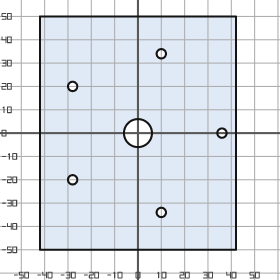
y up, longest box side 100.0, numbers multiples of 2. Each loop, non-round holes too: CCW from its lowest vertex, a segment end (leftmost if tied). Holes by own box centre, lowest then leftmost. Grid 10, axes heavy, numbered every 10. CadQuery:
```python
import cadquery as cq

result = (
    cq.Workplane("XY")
    .moveTo(-42.0, -50.0)
    .lineTo(42.0, -50.0)
    .lineTo(42.0, 50.0)
    .lineTo(-42.0, 50.0)
    .close()
    .moveTo(10.0, -34.0)
    .circle(2.0)
    .moveTo(-28.0, -20.0)
    .circle(2.0)
    .moveTo(0.0, 0.0)
    .circle(6.0)
    .moveTo(36.0, 0.0)
    .circle(2.0)
    .moveTo(-28.0, 20.0)
    .circle(2.0)
    .moveTo(10.0, 34.0)
    .circle(2.0)
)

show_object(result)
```